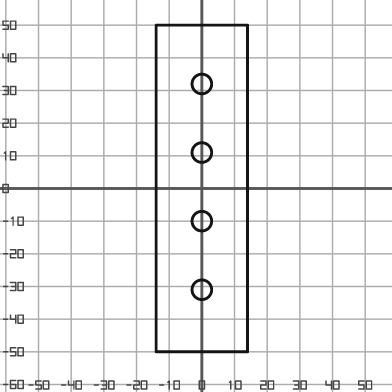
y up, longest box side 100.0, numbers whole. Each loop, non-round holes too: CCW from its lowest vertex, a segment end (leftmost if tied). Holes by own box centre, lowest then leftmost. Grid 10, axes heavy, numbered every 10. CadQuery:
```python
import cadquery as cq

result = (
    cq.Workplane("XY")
    .moveTo(-14.0, -50.0)
    .lineTo(14.0, -50.0)
    .lineTo(14.0, 50.0)
    .lineTo(-14.0, 50.0)
    .close()
    .moveTo(0.0, -31.0)
    .circle(3.0)
    .moveTo(0.0, -10.0)
    .circle(3.0)
    .moveTo(0.0, 11.0)
    .circle(3.0)
    .moveTo(0.0, 32.0)
    .circle(3.0)
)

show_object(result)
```